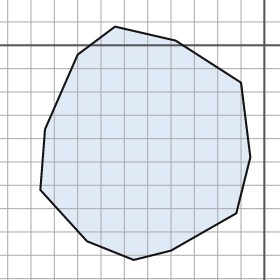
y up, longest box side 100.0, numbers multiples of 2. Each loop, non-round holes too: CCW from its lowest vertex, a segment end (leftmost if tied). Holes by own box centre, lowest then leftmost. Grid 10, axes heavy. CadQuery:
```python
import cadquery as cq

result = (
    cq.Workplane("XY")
    .moveTo(-56.0, -92.0)
    .lineTo(-40.0, -88.0)
    .lineTo(-12.0, -72.0)
    .lineTo(-6.0, -48.0)
    .lineTo(-10.0, -16.0)
    .lineTo(-38.0, 2.0)
    .lineTo(-64.0, 8.0)
    .lineTo(-80.0, -4.0)
    .lineTo(-94.0, -36.0)
    .lineTo(-96.0, -62.0)
    .lineTo(-76.0, -84.0)
    .close()
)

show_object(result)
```